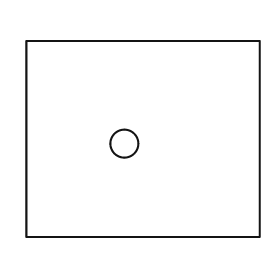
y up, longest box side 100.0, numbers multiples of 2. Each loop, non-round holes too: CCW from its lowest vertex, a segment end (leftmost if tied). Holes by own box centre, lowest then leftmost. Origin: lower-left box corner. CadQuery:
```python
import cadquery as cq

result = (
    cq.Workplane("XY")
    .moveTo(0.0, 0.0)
    .lineTo(100.0, 0.0)
    .lineTo(100.0, 84.0)
    .lineTo(0.0, 84.0)
    .close()
    .moveTo(42.0, 40.0)
    .circle(6.0)
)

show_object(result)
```